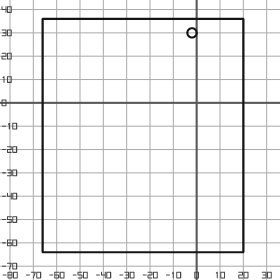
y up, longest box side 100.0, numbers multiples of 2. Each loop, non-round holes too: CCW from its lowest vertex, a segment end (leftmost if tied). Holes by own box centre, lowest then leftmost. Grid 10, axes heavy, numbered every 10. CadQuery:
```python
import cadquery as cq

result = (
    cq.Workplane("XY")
    .moveTo(-66.0, -64.0)
    .lineTo(20.0, -64.0)
    .lineTo(20.0, 36.0)
    .lineTo(-66.0, 36.0)
    .close()
    .moveTo(-2.0, 30.0)
    .circle(2.0)
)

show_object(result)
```